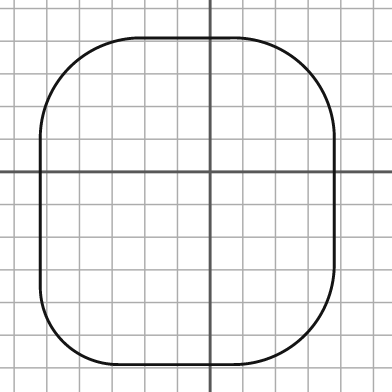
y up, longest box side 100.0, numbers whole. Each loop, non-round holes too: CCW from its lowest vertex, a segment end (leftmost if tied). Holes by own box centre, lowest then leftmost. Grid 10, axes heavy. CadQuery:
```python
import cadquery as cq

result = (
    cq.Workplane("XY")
    .moveTo(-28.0, -59.0)
    .lineTo(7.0, -59.0)
    .threePointArc((29.0, -50.0), (38.0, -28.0))
    .lineTo(38.0, 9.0)
    .threePointArc((29.0, 32.0), (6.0, 41.0))
    .lineTo(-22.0, 41.0)
    .threePointArc((-43.0, 32.0), (-52.0, 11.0))
    .lineTo(-52.0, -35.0)
    .threePointArc((-45.0, -52.0), (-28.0, -59.0))
    .close()
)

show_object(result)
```